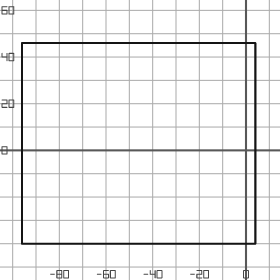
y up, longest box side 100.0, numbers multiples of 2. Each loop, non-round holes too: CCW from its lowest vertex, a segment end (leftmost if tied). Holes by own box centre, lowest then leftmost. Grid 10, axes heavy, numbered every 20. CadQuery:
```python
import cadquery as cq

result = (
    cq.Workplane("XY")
    .moveTo(-96.0, -40.0)
    .lineTo(4.0, -40.0)
    .lineTo(4.0, 46.0)
    .lineTo(-96.0, 46.0)
    .close()
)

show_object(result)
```